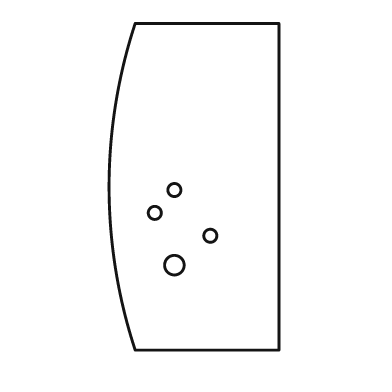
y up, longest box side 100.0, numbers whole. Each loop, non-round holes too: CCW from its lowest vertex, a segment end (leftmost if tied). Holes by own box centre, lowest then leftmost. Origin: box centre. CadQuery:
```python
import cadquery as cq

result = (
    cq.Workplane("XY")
    .moveTo(-18.0, -50.0)
    .lineTo(26.0, -50.0)
    .lineTo(26.0, 50.0)
    .lineTo(-18.0, 50.0)
    .threePointArc((-26.0, 0.0), (-18.0, -50.0))
    .close()
    .moveTo(-6.0, -24.0)
    .circle(3.0)
    .moveTo(5.0, -15.0)
    .circle(2.0)
    .moveTo(-12.0, -8.0)
    .circle(2.0)
    .moveTo(-6.0, -1.0)
    .circle(2.0)
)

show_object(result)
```